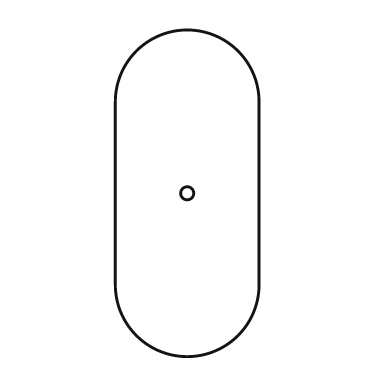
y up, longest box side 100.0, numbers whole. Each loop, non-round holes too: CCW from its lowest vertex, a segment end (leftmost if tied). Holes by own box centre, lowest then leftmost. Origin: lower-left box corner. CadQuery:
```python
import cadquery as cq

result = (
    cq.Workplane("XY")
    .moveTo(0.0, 22.0)
    .threePointArc((22.0, 0.0), (44.0, 22.0))
    .lineTo(44.0, 78.0)
    .threePointArc((22.0, 100.0), (0.0, 78.0))
    .close()
    .moveTo(22.0, 50.0)
    .circle(2.0)
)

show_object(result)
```